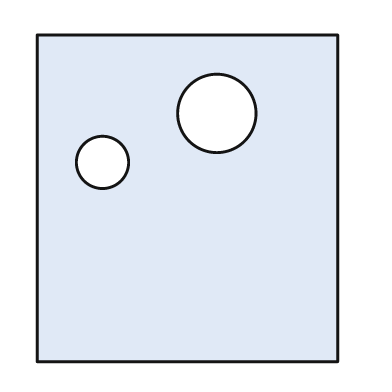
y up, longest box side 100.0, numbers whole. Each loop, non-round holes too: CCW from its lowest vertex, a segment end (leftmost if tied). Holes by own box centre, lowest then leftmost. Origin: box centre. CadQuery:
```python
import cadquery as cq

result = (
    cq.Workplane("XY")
    .moveTo(-46.0, -50.0)
    .lineTo(46.0, -50.0)
    .lineTo(46.0, 50.0)
    .lineTo(-46.0, 50.0)
    .close()
    .moveTo(-26.0, 11.0)
    .circle(8.0)
    .moveTo(9.0, 26.0)
    .circle(12.0)
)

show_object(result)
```